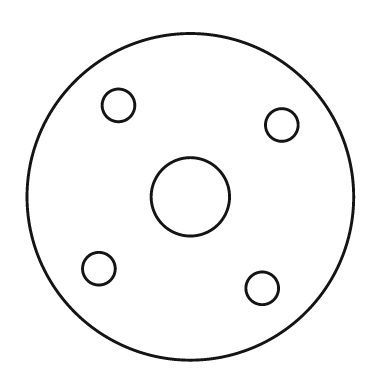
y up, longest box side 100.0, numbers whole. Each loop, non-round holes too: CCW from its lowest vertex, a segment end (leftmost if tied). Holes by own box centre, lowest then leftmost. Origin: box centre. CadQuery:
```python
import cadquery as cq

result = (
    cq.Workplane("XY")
    .moveTo(0.0, 0.0)
    .circle(50.0)
    .moveTo(22.0, -28.0)
    .circle(5.0)
    .moveTo(-28.0, -22.0)
    .circle(5.0)
    .moveTo(0.0, 0.0)
    .circle(12.0)
    .moveTo(28.0, 22.0)
    .circle(5.0)
    .moveTo(-22.0, 28.0)
    .circle(5.0)
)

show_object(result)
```